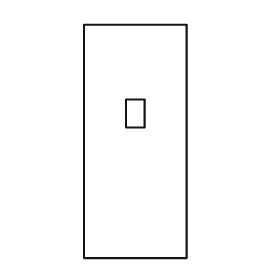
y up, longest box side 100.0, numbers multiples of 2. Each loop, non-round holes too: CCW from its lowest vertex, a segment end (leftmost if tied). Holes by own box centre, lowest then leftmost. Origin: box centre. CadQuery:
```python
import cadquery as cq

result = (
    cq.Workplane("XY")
    .moveTo(-22.0, -50.0)
    .lineTo(22.0, -50.0)
    .lineTo(22.0, 50.0)
    .lineTo(-22.0, 50.0)
    .close()
    .moveTo(-4.0, 6.0)
    .lineTo(4.0, 6.0)
    .lineTo(4.0, 18.0)
    .lineTo(-4.0, 18.0)
    .close()
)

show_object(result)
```